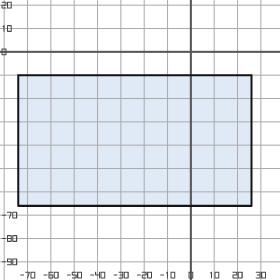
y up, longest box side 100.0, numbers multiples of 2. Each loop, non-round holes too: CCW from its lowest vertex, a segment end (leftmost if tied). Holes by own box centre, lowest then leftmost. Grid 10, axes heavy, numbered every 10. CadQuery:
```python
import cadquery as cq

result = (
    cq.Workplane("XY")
    .moveTo(-74.0, -66.0)
    .lineTo(26.0, -66.0)
    .lineTo(26.0, -10.0)
    .lineTo(-74.0, -10.0)
    .close()
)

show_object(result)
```